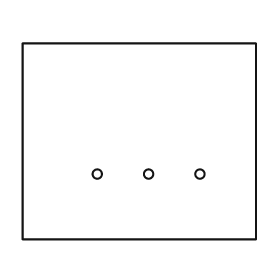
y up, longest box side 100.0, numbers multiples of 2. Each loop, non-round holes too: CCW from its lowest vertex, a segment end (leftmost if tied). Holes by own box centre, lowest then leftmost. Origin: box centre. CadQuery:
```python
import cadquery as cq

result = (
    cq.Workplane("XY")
    .moveTo(-50.0, -42.0)
    .lineTo(50.0, -42.0)
    .lineTo(50.0, 42.0)
    .lineTo(-50.0, 42.0)
    .close()
    .moveTo(-18.0, -14.0)
    .circle(2.0)
    .moveTo(4.0, -14.0)
    .circle(2.0)
    .moveTo(26.0, -14.0)
    .circle(2.0)
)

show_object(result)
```